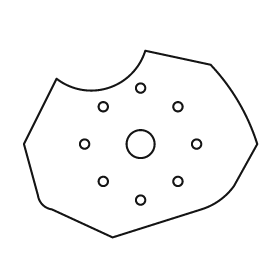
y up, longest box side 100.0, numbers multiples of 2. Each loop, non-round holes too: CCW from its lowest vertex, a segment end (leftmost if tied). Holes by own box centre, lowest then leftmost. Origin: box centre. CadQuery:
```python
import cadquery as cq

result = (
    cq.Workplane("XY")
    .moveTo(-12.0, -40.0)
    .lineTo(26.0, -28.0)
    .threePointArc((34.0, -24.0), (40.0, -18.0))
    .lineTo(50.0, 0.0)
    .threePointArc((42.0, 18.0), (30.0, 34.0))
    .lineTo(2.0, 40.0)
    .threePointArc((-14.0, 24.0), (-36.0, 28.0))
    .lineTo(-50.0, 0.0)
    .lineTo(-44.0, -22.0)
    .threePointArc((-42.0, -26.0), (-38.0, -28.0))
    .close()
    .moveTo(0.0, -24.0)
    .circle(2.0)
    .moveTo(-16.0, -16.0)
    .circle(2.0)
    .moveTo(16.0, -16.0)
    .circle(2.0)
    .moveTo(-24.0, 0.0)
    .circle(2.0)
    .moveTo(0.0, 0.0)
    .circle(6.0)
    .moveTo(24.0, 0.0)
    .circle(2.0)
    .moveTo(-16.0, 16.0)
    .circle(2.0)
    .moveTo(16.0, 16.0)
    .circle(2.0)
    .moveTo(0.0, 24.0)
    .circle(2.0)
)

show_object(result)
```